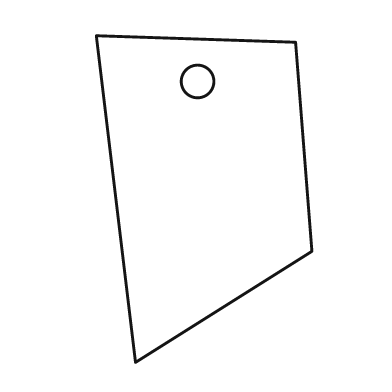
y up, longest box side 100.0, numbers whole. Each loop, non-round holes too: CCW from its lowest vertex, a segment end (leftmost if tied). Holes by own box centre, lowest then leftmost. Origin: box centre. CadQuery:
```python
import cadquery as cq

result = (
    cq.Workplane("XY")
    .moveTo(-21.0, -50.0)
    .lineTo(33.0, -16.0)
    .lineTo(28.0, 48.0)
    .lineTo(-33.0, 50.0)
    .close()
    .moveTo(-2.0, 36.0)
    .circle(5.0)
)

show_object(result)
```